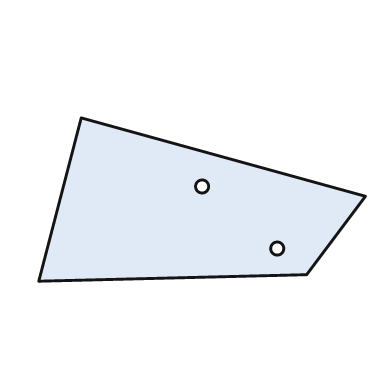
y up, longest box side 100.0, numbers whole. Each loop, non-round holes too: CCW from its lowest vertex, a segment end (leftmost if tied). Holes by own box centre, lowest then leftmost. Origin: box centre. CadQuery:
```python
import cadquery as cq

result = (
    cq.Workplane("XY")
    .moveTo(-50.0, -25.0)
    .lineTo(32.0, -23.0)
    .lineTo(50.0, 1.0)
    .lineTo(-37.0, 25.0)
    .close()
    .moveTo(23.0, -15.0)
    .circle(2.0)
    .moveTo(0.0, 4.0)
    .circle(2.0)
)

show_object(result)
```